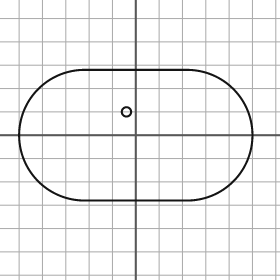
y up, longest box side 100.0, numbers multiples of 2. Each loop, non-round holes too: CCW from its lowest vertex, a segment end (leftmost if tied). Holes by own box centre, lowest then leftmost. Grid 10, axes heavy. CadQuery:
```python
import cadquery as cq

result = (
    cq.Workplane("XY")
    .moveTo(-22.0, -28.0)
    .lineTo(22.0, -28.0)
    .threePointArc((50.0, 0.0), (22.0, 28.0))
    .lineTo(-22.0, 28.0)
    .threePointArc((-50.0, 0.0), (-22.0, -28.0))
    .close()
    .moveTo(-4.0, 10.0)
    .circle(2.0)
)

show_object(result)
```